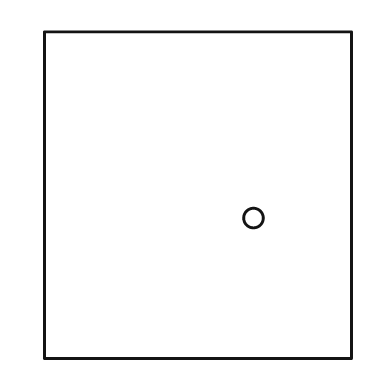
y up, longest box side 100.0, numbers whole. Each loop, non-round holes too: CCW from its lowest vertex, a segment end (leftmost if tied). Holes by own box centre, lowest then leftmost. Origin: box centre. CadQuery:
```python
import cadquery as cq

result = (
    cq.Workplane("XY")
    .moveTo(-47.0, -50.0)
    .lineTo(47.0, -50.0)
    .lineTo(47.0, 50.0)
    .lineTo(-47.0, 50.0)
    .close()
    .moveTo(17.0, -7.0)
    .circle(3.0)
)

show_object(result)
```